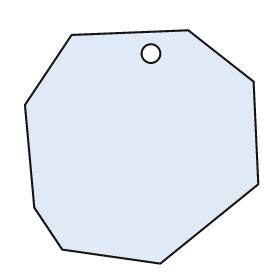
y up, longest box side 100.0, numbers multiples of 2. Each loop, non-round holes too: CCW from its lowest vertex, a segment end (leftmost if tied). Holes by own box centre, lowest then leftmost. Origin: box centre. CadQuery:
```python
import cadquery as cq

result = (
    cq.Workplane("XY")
    .moveTo(8.0, -50.0)
    .lineTo(50.0, -16.0)
    .lineTo(48.0, 28.0)
    .lineTo(20.0, 50.0)
    .lineTo(-30.0, 48.0)
    .lineTo(-50.0, 18.0)
    .lineTo(-46.0, -26.0)
    .lineTo(-34.0, -44.0)
    .close()
    .moveTo(4.0, 40.0)
    .circle(4.0)
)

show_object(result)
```